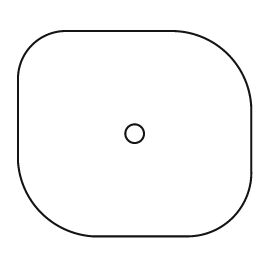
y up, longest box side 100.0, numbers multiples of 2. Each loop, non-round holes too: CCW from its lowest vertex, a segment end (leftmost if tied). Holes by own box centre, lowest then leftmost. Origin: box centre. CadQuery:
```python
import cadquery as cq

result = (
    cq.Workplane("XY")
    .moveTo(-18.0, -44.0)
    .lineTo(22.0, -44.0)
    .threePointArc((42.0, -36.0), (50.0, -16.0))
    .lineTo(50.0, 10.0)
    .threePointArc((40.0, 34.0), (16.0, 44.0))
    .lineTo(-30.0, 44.0)
    .threePointArc((-44.0, 38.0), (-50.0, 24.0))
    .lineTo(-50.0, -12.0)
    .threePointArc((-40.0, -34.0), (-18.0, -44.0))
    .close()
    .moveTo(0.0, 0.0)
    .circle(4.0)
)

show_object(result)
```